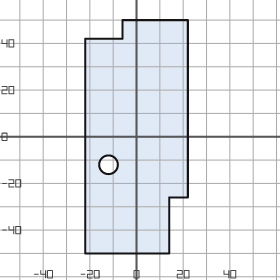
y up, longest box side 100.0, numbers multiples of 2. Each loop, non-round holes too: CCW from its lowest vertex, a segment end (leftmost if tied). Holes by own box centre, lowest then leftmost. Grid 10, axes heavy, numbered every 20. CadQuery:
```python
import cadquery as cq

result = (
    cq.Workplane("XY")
    .moveTo(-22.0, -50.0)
    .lineTo(14.0, -50.0)
    .lineTo(14.0, -26.0)
    .lineTo(22.0, -26.0)
    .lineTo(22.0, 50.0)
    .lineTo(-6.0, 50.0)
    .lineTo(-6.0, 42.0)
    .lineTo(-22.0, 42.0)
    .close()
    .moveTo(-12.0, -12.0)
    .circle(4.0)
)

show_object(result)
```